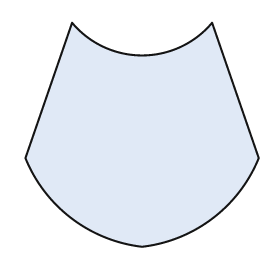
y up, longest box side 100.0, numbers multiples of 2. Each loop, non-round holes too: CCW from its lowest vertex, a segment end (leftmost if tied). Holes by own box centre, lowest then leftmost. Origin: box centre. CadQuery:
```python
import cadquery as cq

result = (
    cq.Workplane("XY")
    .moveTo(0.0, -48.0)
    .threePointArc((30.0, -36.0), (50.0, -10.0))
    .lineTo(30.0, 48.0)
    .threePointArc((0.0, 34.0), (-30.0, 48.0))
    .lineTo(-50.0, -10.0)
    .threePointArc((-30.0, -36.0), (0.0, -48.0))
    .close()
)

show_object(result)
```